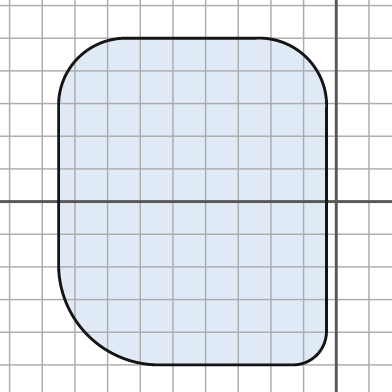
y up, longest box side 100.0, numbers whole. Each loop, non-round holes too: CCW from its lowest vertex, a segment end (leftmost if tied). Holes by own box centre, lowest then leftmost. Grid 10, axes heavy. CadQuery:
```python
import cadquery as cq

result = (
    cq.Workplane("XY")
    .moveTo(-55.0, -50.0)
    .lineTo(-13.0, -50.0)
    .threePointArc((-6.0, -47.0), (-3.0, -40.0))
    .lineTo(-3.0, 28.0)
    .threePointArc((-9.0, 44.0), (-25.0, 50.0))
    .lineTo(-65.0, 50.0)
    .threePointArc((-79.0, 44.0), (-85.0, 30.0))
    .lineTo(-85.0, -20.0)
    .threePointArc((-76.0, -41.0), (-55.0, -50.0))
    .close()
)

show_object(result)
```